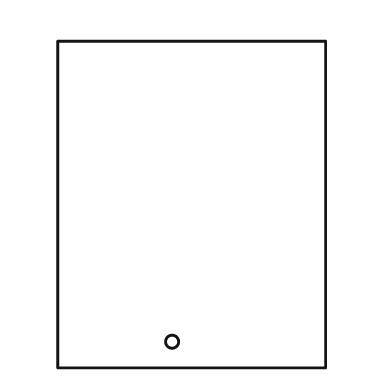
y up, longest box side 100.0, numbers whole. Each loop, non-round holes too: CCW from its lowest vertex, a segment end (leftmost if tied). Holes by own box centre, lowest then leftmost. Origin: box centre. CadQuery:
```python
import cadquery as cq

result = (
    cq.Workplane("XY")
    .moveTo(-41.0, -50.0)
    .lineTo(41.0, -50.0)
    .lineTo(41.0, 50.0)
    .lineTo(-41.0, 50.0)
    .close()
    .moveTo(-6.0, -42.0)
    .circle(2.0)
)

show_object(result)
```